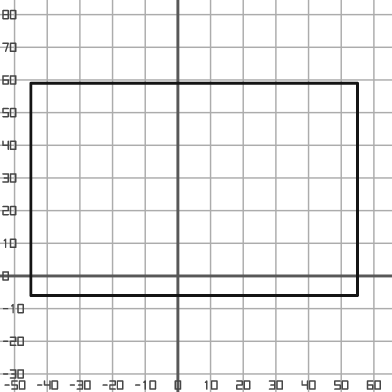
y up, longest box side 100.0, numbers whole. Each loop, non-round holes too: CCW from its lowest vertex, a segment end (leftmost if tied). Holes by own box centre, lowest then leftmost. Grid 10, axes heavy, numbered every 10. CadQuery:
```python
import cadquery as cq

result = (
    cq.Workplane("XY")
    .moveTo(-45.0, -6.0)
    .lineTo(55.0, -6.0)
    .lineTo(55.0, 59.0)
    .lineTo(-45.0, 59.0)
    .close()
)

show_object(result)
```